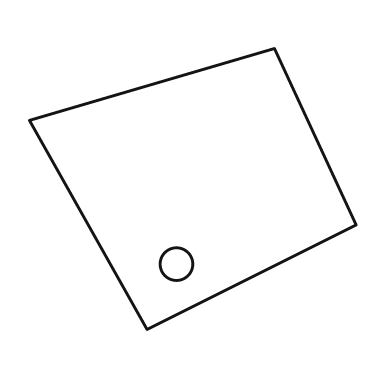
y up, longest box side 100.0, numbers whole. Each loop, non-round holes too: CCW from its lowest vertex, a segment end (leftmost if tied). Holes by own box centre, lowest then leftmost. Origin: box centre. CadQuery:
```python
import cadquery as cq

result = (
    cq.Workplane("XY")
    .moveTo(-14.0, -43.0)
    .lineTo(50.0, -11.0)
    .lineTo(25.0, 43.0)
    .lineTo(-50.0, 21.0)
    .close()
    .moveTo(-5.0, -23.0)
    .circle(5.0)
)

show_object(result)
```